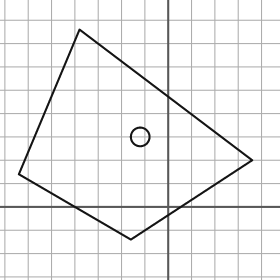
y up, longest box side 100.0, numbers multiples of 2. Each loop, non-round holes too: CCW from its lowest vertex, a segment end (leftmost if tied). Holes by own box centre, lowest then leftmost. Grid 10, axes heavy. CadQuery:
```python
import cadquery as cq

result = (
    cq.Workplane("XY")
    .moveTo(-16.0, -14.0)
    .lineTo(36.0, 20.0)
    .lineTo(-38.0, 76.0)
    .lineTo(-64.0, 14.0)
    .close()
    .moveTo(-12.0, 30.0)
    .circle(4.0)
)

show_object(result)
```